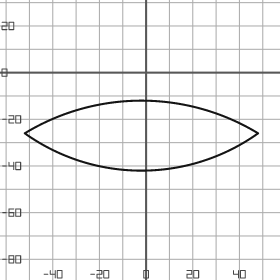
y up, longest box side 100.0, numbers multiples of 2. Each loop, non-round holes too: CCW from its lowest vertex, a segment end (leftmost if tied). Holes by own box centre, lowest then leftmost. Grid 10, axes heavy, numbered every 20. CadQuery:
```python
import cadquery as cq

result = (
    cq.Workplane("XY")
    .moveTo(-52.0, -26.0)
    .threePointArc((-2.0, -42.0), (48.0, -26.0))
    .threePointArc((-2.0, -12.0), (-52.0, -26.0))
    .close()
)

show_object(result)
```